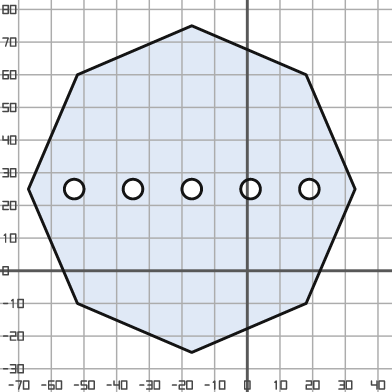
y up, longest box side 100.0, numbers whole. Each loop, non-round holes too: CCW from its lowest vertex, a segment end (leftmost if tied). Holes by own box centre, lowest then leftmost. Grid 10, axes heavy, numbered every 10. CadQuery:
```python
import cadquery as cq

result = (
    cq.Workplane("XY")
    .moveTo(-17.0, -25.0)
    .lineTo(18.0, -10.0)
    .lineTo(33.0, 25.0)
    .lineTo(18.0, 60.0)
    .lineTo(-17.0, 75.0)
    .lineTo(-52.0, 60.0)
    .lineTo(-67.0, 25.0)
    .lineTo(-52.0, -10.0)
    .close()
    .moveTo(-53.0, 25.0)
    .circle(3.0)
    .moveTo(-35.0, 25.0)
    .circle(3.0)
    .moveTo(-17.0, 25.0)
    .circle(3.0)
    .moveTo(1.0, 25.0)
    .circle(3.0)
    .moveTo(19.0, 25.0)
    .circle(3.0)
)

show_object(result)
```